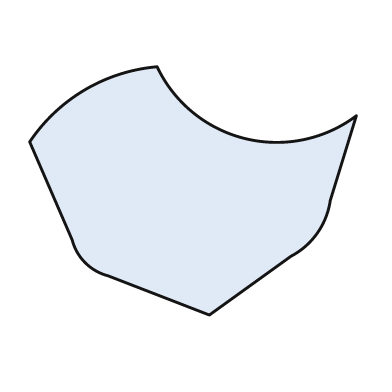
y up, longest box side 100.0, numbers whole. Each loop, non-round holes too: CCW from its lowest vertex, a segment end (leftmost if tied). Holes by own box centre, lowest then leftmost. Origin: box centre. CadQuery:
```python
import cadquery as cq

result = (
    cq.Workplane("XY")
    .moveTo(5.0, -38.0)
    .lineTo(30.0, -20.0)
    .threePointArc((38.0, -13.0), (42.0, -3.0))
    .lineTo(50.0, 23.0)
    .threePointArc((16.0, 16.0), (-11.0, 38.0))
    .threePointArc((-33.0, 31.0), (-50.0, 15.0))
    .lineTo(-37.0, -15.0)
    .threePointArc((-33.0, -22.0), (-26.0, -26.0))
    .close()
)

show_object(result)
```